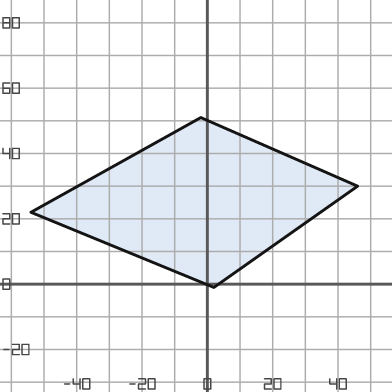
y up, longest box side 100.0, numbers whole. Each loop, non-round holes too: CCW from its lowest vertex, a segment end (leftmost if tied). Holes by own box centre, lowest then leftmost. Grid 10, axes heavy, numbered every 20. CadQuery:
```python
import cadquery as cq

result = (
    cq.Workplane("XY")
    .moveTo(2.0, -1.0)
    .lineTo(46.0, 30.0)
    .lineTo(-2.0, 51.0)
    .lineTo(-54.0, 22.0)
    .close()
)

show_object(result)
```